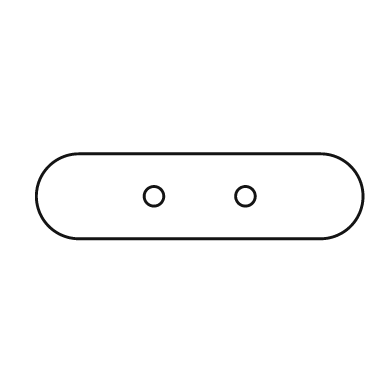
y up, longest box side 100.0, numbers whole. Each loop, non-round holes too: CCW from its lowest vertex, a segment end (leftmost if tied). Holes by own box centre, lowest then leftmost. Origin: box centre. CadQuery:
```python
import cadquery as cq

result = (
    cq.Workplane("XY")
    .moveTo(-37.0, -13.0)
    .lineTo(37.0, -13.0)
    .threePointArc((50.0, 0.0), (37.0, 13.0))
    .lineTo(-37.0, 13.0)
    .threePointArc((-50.0, 0.0), (-37.0, -13.0))
    .close()
    .moveTo(-14.0, 0.0)
    .circle(3.0)
    .moveTo(14.0, 0.0)
    .circle(3.0)
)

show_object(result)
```